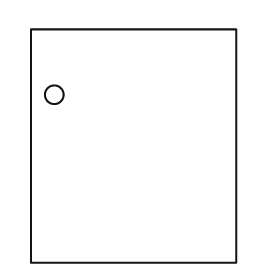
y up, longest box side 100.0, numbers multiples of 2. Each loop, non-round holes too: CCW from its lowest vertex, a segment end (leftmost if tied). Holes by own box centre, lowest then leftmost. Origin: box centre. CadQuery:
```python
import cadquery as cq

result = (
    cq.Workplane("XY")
    .moveTo(-44.0, -50.0)
    .lineTo(44.0, -50.0)
    .lineTo(44.0, 50.0)
    .lineTo(-44.0, 50.0)
    .close()
    .moveTo(-34.0, 22.0)
    .circle(4.0)
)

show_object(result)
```